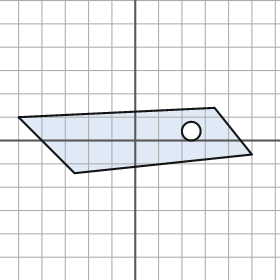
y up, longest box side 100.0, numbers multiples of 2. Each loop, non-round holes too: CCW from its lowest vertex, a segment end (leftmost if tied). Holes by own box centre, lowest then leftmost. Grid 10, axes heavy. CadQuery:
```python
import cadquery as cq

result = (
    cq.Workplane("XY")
    .moveTo(-26.0, -14.0)
    .lineTo(50.0, -6.0)
    .lineTo(34.0, 14.0)
    .lineTo(-50.0, 10.0)
    .close()
    .moveTo(24.0, 4.0)
    .circle(4.0)
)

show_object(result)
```